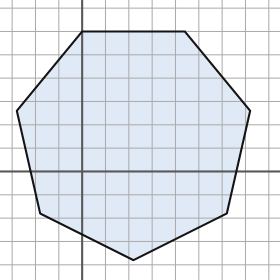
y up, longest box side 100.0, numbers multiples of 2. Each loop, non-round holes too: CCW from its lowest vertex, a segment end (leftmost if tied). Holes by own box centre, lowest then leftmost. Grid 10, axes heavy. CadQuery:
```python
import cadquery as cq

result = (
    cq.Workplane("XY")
    .moveTo(22.0, -38.0)
    .lineTo(62.0, -18.0)
    .lineTo(72.0, 26.0)
    .lineTo(44.0, 60.0)
    .lineTo(0.0, 60.0)
    .lineTo(-28.0, 26.0)
    .lineTo(-18.0, -18.0)
    .close()
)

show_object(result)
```